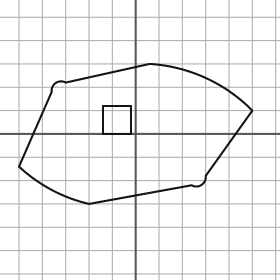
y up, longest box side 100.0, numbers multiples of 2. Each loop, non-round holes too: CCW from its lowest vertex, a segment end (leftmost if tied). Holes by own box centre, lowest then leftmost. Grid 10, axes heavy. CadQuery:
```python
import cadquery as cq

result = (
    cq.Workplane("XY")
    .moveTo(-20.0, -30.0)
    .lineTo(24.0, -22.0)
    .threePointArc((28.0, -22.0), (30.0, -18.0))
    .lineTo(50.0, 10.0)
    .threePointArc((30.0, 24.0), (6.0, 30.0))
    .lineTo(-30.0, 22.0)
    .threePointArc((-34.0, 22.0), (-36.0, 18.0))
    .lineTo(-50.0, -14.0)
    .threePointArc((-36.0, -24.0), (-20.0, -30.0))
    .close()
    .moveTo(-14.0, 0.0)
    .lineTo(-2.0, 0.0)
    .lineTo(-2.0, 12.0)
    .lineTo(-14.0, 12.0)
    .close()
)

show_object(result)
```